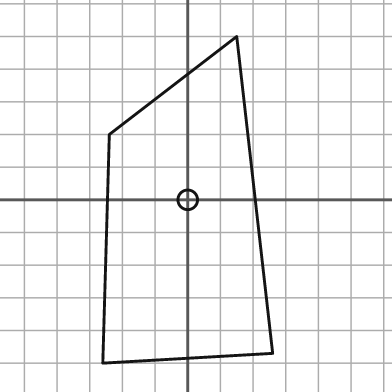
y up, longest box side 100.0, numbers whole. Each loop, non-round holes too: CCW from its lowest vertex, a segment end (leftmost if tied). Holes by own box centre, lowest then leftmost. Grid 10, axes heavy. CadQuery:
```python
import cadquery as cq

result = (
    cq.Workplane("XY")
    .moveTo(-26.0, -50.0)
    .lineTo(26.0, -47.0)
    .lineTo(15.0, 50.0)
    .lineTo(-24.0, 20.0)
    .close()
    .moveTo(0.0, 0.0)
    .circle(3.0)
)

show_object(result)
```